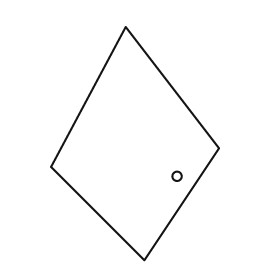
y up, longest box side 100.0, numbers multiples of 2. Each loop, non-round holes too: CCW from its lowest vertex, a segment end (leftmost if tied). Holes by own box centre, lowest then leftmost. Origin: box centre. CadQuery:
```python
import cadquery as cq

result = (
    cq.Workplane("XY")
    .moveTo(4.0, -50.0)
    .lineTo(36.0, -2.0)
    .lineTo(-4.0, 50.0)
    .lineTo(-36.0, -10.0)
    .close()
    .moveTo(18.0, -14.0)
    .circle(2.0)
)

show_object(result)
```